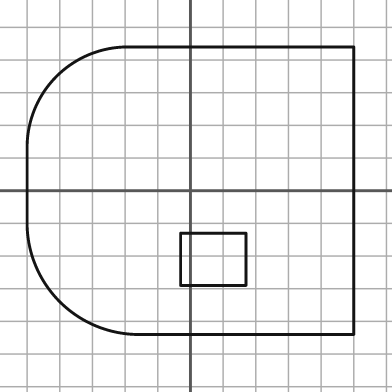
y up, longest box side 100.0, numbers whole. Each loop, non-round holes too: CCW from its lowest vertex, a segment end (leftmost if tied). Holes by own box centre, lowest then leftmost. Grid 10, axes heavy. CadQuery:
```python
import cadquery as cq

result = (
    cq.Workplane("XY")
    .moveTo(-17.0, -44.0)
    .lineTo(50.0, -44.0)
    .lineTo(50.0, 44.0)
    .lineTo(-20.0, 44.0)
    .threePointArc((-41.0, 35.0), (-50.0, 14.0))
    .lineTo(-50.0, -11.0)
    .threePointArc((-40.0, -34.0), (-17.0, -44.0))
    .close()
    .moveTo(-3.0, -29.0)
    .lineTo(17.0, -29.0)
    .lineTo(17.0, -13.0)
    .lineTo(-3.0, -13.0)
    .close()
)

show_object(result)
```